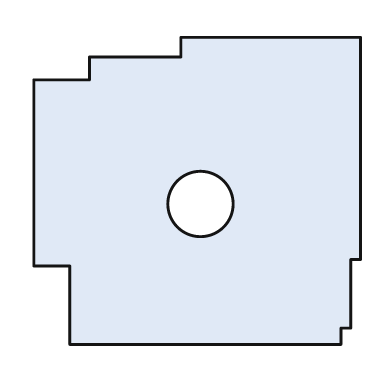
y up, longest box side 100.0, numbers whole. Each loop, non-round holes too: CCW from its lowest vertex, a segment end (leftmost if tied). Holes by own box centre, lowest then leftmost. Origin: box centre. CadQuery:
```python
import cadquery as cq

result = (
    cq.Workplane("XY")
    .moveTo(-39.0, -47.0)
    .lineTo(44.0, -47.0)
    .lineTo(44.0, -42.0)
    .lineTo(47.0, -42.0)
    .lineTo(47.0, -21.0)
    .lineTo(50.0, -21.0)
    .lineTo(50.0, 47.0)
    .lineTo(-5.0, 47.0)
    .lineTo(-5.0, 41.0)
    .lineTo(-33.0, 41.0)
    .lineTo(-33.0, 34.0)
    .lineTo(-50.0, 34.0)
    .lineTo(-50.0, -23.0)
    .lineTo(-39.0, -23.0)
    .close()
    .moveTo(1.0, -4.0)
    .circle(10.0)
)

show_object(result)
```